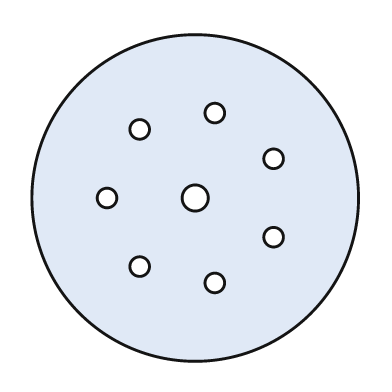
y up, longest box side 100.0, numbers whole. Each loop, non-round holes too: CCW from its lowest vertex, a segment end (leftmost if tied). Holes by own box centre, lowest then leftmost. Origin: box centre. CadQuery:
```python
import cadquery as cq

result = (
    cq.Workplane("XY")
    .moveTo(0.0, 0.0)
    .circle(50.0)
    .moveTo(6.0, -26.0)
    .circle(3.0)
    .moveTo(-17.0, -21.0)
    .circle(3.0)
    .moveTo(24.0, -12.0)
    .circle(3.0)
    .moveTo(-27.0, 0.0)
    .circle(3.0)
    .moveTo(0.0, 0.0)
    .circle(4.0)
    .moveTo(24.0, 12.0)
    .circle(3.0)
    .moveTo(-17.0, 21.0)
    .circle(3.0)
    .moveTo(6.0, 26.0)
    .circle(3.0)
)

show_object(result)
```